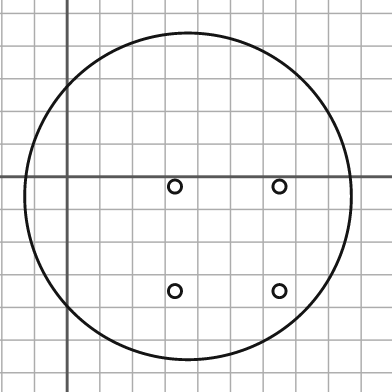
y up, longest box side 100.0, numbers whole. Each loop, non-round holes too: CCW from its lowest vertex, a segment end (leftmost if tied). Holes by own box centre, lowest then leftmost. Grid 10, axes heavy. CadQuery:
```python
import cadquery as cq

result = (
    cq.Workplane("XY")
    .moveTo(37.0, -6.0)
    .circle(50.0)
    .moveTo(33.0, -35.0)
    .circle(2.0)
    .moveTo(65.0, -35.0)
    .circle(2.0)
    .moveTo(33.0, -3.0)
    .circle(2.0)
    .moveTo(65.0, -3.0)
    .circle(2.0)
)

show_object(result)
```